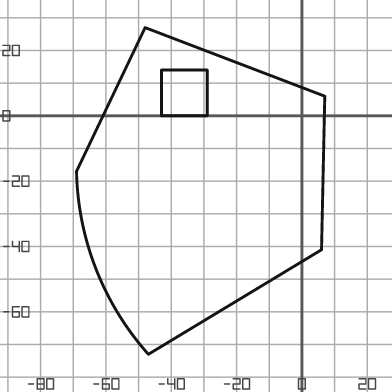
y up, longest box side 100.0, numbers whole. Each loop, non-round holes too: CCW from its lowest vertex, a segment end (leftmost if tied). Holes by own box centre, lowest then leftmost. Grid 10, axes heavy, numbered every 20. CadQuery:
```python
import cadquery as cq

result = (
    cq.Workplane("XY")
    .moveTo(-47.0, -73.0)
    .lineTo(6.0, -41.0)
    .lineTo(7.0, 6.0)
    .lineTo(-48.0, 27.0)
    .lineTo(-69.0, -17.0)
    .threePointArc((-63.0, -47.0), (-47.0, -73.0))
    .close()
    .moveTo(-43.0, 0.0)
    .lineTo(-29.0, 0.0)
    .lineTo(-29.0, 14.0)
    .lineTo(-43.0, 14.0)
    .close()
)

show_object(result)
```